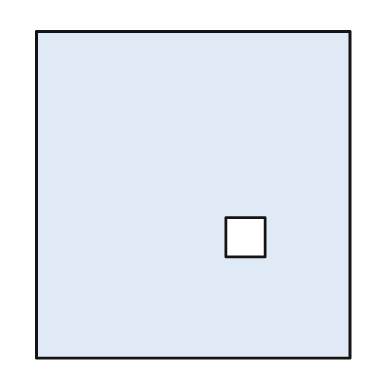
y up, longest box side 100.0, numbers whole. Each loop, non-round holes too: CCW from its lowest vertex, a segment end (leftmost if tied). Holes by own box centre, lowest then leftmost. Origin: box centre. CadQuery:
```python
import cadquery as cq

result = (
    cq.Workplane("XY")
    .moveTo(-48.0, -50.0)
    .lineTo(48.0, -50.0)
    .lineTo(48.0, 50.0)
    .lineTo(-48.0, 50.0)
    .close()
    .moveTo(10.0, -19.0)
    .lineTo(22.0, -19.0)
    .lineTo(22.0, -7.0)
    .lineTo(10.0, -7.0)
    .close()
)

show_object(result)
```